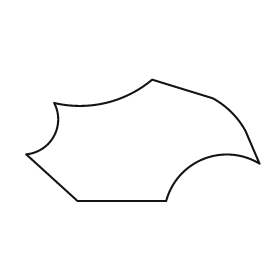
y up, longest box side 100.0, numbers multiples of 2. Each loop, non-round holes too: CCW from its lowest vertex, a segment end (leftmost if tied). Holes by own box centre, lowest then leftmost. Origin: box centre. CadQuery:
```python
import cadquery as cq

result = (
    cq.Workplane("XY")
    .moveTo(-28.0, -26.0)
    .lineTo(10.0, -26.0)
    .threePointArc((26.0, -8.0), (50.0, -10.0))
    .lineTo(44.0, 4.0)
    .threePointArc((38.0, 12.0), (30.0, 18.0))
    .lineTo(4.0, 26.0)
    .threePointArc((-16.0, 16.0), (-38.0, 16.0))
    .threePointArc((-38.0, 2.0), (-50.0, -6.0))
    .close()
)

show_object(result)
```